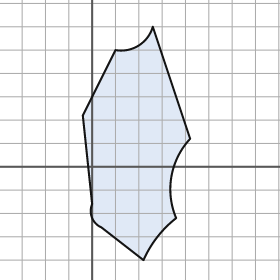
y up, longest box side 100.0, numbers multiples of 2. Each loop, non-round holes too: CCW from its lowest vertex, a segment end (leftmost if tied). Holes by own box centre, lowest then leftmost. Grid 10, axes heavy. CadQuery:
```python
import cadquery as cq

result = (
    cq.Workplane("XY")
    .moveTo(22.0, -40.0)
    .threePointArc((28.0, -30.0), (36.0, -22.0))
    .threePointArc((34.0, -4.0), (42.0, 12.0))
    .lineTo(26.0, 60.0)
    .threePointArc((20.0, 52.0), (10.0, 50.0))
    .lineTo(-4.0, 22.0)
    .lineTo(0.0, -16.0)
    .threePointArc((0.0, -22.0), (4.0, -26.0))
    .close()
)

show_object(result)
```